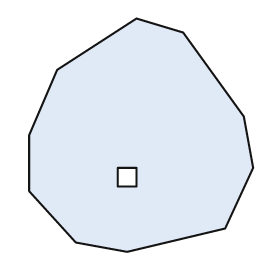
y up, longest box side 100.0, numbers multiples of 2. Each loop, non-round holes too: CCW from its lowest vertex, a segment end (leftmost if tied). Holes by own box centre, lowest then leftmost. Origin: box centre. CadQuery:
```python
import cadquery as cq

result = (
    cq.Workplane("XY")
    .moveTo(-6.0, -50.0)
    .lineTo(36.0, -40.0)
    .lineTo(48.0, -14.0)
    .lineTo(44.0, 8.0)
    .lineTo(18.0, 44.0)
    .lineTo(-2.0, 50.0)
    .lineTo(-36.0, 28.0)
    .lineTo(-48.0, 0.0)
    .lineTo(-48.0, -24.0)
    .lineTo(-28.0, -46.0)
    .close()
    .moveTo(-10.0, -22.0)
    .lineTo(-2.0, -22.0)
    .lineTo(-2.0, -14.0)
    .lineTo(-10.0, -14.0)
    .close()
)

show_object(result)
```